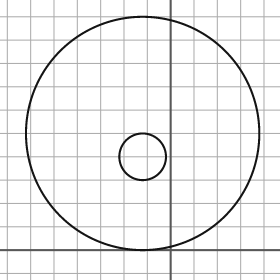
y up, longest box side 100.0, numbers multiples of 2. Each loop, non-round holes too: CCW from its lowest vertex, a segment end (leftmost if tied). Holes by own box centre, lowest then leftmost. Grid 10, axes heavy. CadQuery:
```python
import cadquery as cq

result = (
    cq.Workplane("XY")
    .moveTo(-12.0, 50.0)
    .circle(50.0)
    .moveTo(-12.0, 40.0)
    .circle(10.0)
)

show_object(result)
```